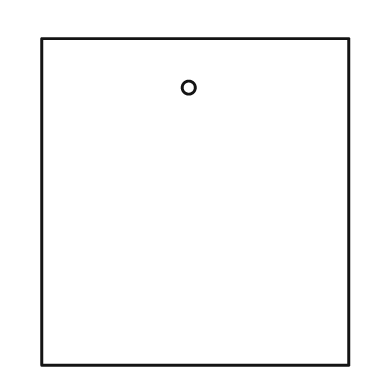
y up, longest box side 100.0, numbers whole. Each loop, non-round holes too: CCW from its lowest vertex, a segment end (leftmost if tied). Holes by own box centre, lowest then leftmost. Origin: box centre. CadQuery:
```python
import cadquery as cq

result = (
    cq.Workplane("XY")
    .moveTo(-47.0, -50.0)
    .lineTo(47.0, -50.0)
    .lineTo(47.0, 50.0)
    .lineTo(-47.0, 50.0)
    .close()
    .moveTo(-2.0, 35.0)
    .circle(2.0)
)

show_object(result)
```